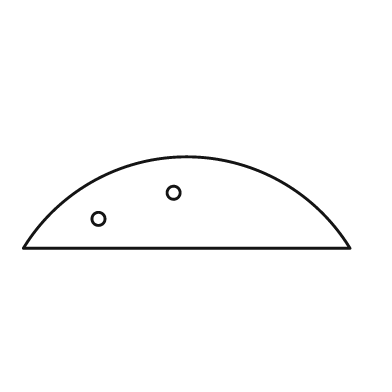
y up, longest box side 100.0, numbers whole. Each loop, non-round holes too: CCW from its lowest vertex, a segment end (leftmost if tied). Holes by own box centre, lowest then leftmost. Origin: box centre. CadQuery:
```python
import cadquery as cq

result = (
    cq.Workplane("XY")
    .moveTo(-50.0, -14.0)
    .lineTo(50.0, -14.0)
    .threePointArc((0.0, 14.0), (-50.0, -14.0))
    .close()
    .moveTo(-27.0, -5.0)
    .circle(2.0)
    .moveTo(-4.0, 3.0)
    .circle(2.0)
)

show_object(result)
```